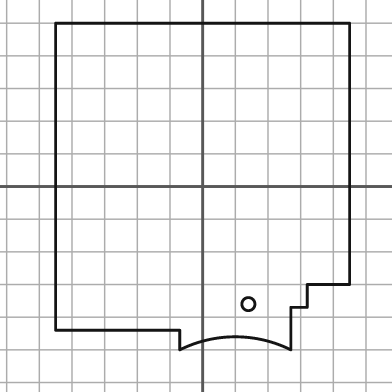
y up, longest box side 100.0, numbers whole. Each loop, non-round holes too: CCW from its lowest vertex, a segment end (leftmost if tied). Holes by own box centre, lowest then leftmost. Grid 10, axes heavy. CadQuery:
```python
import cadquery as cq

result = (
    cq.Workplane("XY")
    .moveTo(-7.0, -50.0)
    .threePointArc((10.0, -46.0), (27.0, -50.0))
    .lineTo(27.0, -37.0)
    .lineTo(32.0, -37.0)
    .lineTo(32.0, -30.0)
    .lineTo(45.0, -30.0)
    .lineTo(45.0, 50.0)
    .lineTo(-45.0, 50.0)
    .lineTo(-45.0, -44.0)
    .lineTo(-7.0, -44.0)
    .close()
    .moveTo(14.0, -36.0)
    .circle(2.0)
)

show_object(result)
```